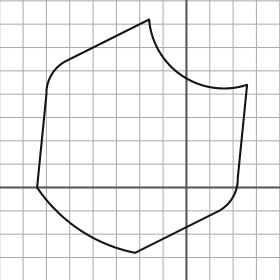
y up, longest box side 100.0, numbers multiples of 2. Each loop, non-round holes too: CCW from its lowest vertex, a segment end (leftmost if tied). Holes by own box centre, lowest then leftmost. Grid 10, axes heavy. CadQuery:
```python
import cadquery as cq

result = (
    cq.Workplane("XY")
    .moveTo(-22.0, -28.0)
    .lineTo(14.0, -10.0)
    .threePointArc((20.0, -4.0), (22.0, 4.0))
    .lineTo(26.0, 44.0)
    .threePointArc((-2.0, 48.0), (-16.0, 72.0))
    .lineTo(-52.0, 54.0)
    .threePointArc((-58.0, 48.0), (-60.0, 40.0))
    .lineTo(-64.0, 0.0)
    .threePointArc((-46.0, -18.0), (-22.0, -28.0))
    .close()
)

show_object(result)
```